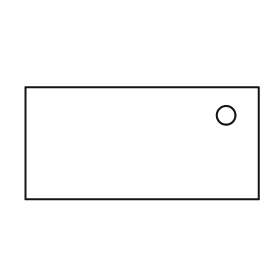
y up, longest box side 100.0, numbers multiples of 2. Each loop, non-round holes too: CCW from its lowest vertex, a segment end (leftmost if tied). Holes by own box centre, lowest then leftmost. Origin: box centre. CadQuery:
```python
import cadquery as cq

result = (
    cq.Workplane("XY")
    .moveTo(-50.0, -24.0)
    .lineTo(50.0, -24.0)
    .lineTo(50.0, 24.0)
    .lineTo(-50.0, 24.0)
    .close()
    .moveTo(36.0, 12.0)
    .circle(4.0)
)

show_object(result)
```